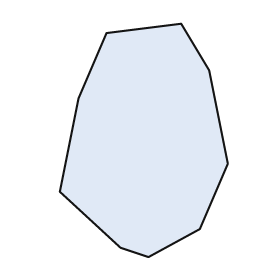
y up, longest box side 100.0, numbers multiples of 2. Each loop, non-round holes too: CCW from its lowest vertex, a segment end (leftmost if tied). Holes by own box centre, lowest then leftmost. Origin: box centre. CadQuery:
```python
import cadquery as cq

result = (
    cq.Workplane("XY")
    .moveTo(2.0, -50.0)
    .lineTo(24.0, -38.0)
    .lineTo(36.0, -10.0)
    .lineTo(28.0, 30.0)
    .lineTo(16.0, 50.0)
    .lineTo(-16.0, 46.0)
    .lineTo(-28.0, 18.0)
    .lineTo(-36.0, -22.0)
    .lineTo(-10.0, -46.0)
    .close()
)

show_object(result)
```